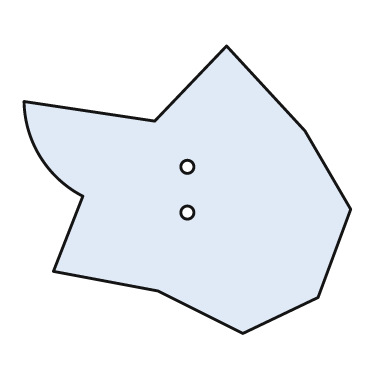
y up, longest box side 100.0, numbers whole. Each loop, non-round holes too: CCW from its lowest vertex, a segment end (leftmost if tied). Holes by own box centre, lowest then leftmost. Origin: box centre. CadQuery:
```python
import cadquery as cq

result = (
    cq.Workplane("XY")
    .moveTo(17.0, -44.0)
    .lineTo(40.0, -33.0)
    .lineTo(50.0, -6.0)
    .lineTo(36.0, 18.0)
    .lineTo(12.0, 44.0)
    .lineTo(-10.0, 21.0)
    .lineTo(-50.0, 27.0)
    .threePointArc((-45.0, 10.0), (-32.0, -2.0))
    .lineTo(-41.0, -25.0)
    .lineTo(-9.0, -31.0)
    .close()
    .moveTo(0.0, -7.0)
    .circle(2.0)
    .moveTo(0.0, 7.0)
    .circle(2.0)
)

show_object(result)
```